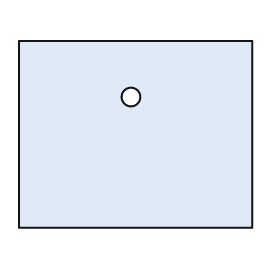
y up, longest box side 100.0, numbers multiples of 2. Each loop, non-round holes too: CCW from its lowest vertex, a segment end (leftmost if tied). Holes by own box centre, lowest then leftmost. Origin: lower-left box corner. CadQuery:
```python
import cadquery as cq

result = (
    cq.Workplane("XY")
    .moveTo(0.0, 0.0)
    .lineTo(100.0, 0.0)
    .lineTo(100.0, 80.0)
    .lineTo(0.0, 80.0)
    .close()
    .moveTo(48.0, 56.0)
    .circle(4.0)
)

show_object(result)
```